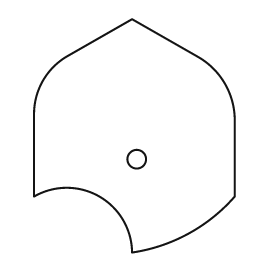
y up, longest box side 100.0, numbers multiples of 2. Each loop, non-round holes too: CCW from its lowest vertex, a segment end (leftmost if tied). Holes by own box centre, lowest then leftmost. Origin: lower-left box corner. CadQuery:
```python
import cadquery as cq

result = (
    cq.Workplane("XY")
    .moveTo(42.0, 0.0)
    .threePointArc((66.0, 8.0), (86.0, 24.0))
    .lineTo(86.0, 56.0)
    .threePointArc((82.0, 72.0), (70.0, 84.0))
    .lineTo(42.0, 100.0)
    .lineTo(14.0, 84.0)
    .threePointArc((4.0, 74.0), (0.0, 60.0))
    .lineTo(0.0, 24.0)
    .threePointArc((28.0, 24.0), (42.0, 0.0))
    .close()
    .moveTo(44.0, 40.0)
    .circle(4.0)
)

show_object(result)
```